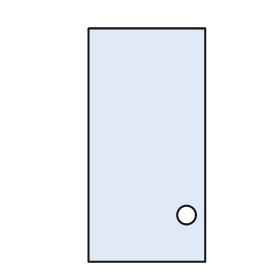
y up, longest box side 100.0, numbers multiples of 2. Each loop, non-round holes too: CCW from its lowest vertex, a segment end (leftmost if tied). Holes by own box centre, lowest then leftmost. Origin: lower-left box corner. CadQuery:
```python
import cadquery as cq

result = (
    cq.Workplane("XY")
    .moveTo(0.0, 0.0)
    .lineTo(50.0, 0.0)
    .lineTo(50.0, 100.0)
    .lineTo(0.0, 100.0)
    .close()
    .moveTo(42.0, 20.0)
    .circle(4.0)
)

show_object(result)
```